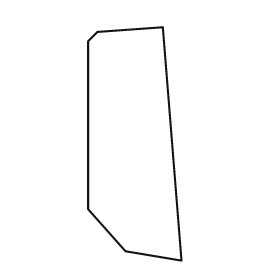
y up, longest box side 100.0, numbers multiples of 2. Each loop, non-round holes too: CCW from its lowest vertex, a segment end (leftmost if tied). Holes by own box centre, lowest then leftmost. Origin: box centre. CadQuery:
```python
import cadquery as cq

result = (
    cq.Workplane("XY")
    .moveTo(20.0, -50.0)
    .lineTo(12.0, 50.0)
    .lineTo(-16.0, 48.0)
    .lineTo(-20.0, 44.0)
    .lineTo(-20.0, -28.0)
    .lineTo(-4.0, -46.0)
    .close()
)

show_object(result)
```